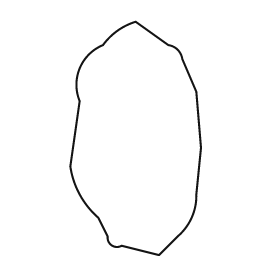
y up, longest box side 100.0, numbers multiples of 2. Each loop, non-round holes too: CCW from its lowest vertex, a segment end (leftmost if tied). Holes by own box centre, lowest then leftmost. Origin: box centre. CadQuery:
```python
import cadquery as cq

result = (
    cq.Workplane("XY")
    .moveTo(10.0, -50.0)
    .lineTo(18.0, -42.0)
    .threePointArc((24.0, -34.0), (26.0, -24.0))
    .lineTo(28.0, -4.0)
    .lineTo(26.0, 20.0)
    .lineTo(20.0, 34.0)
    .threePointArc((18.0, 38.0), (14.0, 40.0))
    .lineTo(0.0, 50.0)
    .threePointArc((-8.0, 46.0), (-14.0, 40.0))
    .threePointArc((-24.0, 30.0), (-24.0, 16.0))
    .lineTo(-28.0, -12.0)
    .threePointArc((-24.0, -24.0), (-16.0, -34.0))
    .lineTo(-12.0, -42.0)
    .threePointArc((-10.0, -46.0), (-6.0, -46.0))
    .close()
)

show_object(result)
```